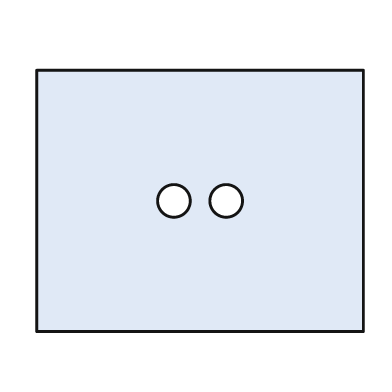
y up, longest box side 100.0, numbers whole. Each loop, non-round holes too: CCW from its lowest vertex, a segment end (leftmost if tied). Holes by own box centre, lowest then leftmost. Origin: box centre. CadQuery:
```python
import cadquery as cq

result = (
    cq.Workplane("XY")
    .moveTo(-50.0, -40.0)
    .lineTo(50.0, -40.0)
    .lineTo(50.0, 40.0)
    .lineTo(-50.0, 40.0)
    .close()
    .moveTo(-8.0, 0.0)
    .circle(5.0)
    .moveTo(8.0, 0.0)
    .circle(5.0)
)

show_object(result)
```